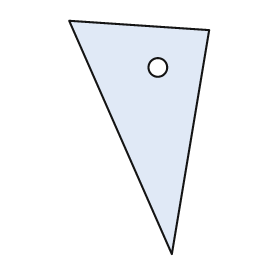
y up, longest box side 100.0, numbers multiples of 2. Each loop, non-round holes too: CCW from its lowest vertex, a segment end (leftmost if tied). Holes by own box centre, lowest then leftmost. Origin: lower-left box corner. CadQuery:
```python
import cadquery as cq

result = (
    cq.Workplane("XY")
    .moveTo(44.0, 0.0)
    .lineTo(60.0, 96.0)
    .lineTo(0.0, 100.0)
    .close()
    .moveTo(38.0, 80.0)
    .circle(4.0)
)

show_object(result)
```